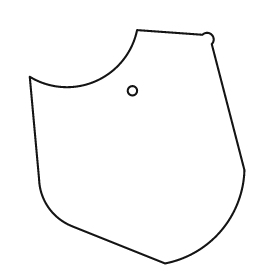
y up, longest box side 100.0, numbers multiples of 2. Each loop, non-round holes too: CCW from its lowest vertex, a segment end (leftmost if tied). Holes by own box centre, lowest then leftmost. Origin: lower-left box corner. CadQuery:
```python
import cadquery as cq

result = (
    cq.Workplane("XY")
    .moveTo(58.0, 0.0)
    .threePointArc((82.0, 14.0), (92.0, 40.0))
    .lineTo(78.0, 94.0)
    .threePointArc((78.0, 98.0), (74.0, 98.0))
    .lineTo(46.0, 100.0)
    .threePointArc((28.0, 78.0), (0.0, 80.0))
    .lineTo(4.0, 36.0)
    .threePointArc((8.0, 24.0), (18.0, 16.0))
    .close()
    .moveTo(44.0, 74.0)
    .circle(2.0)
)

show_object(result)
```